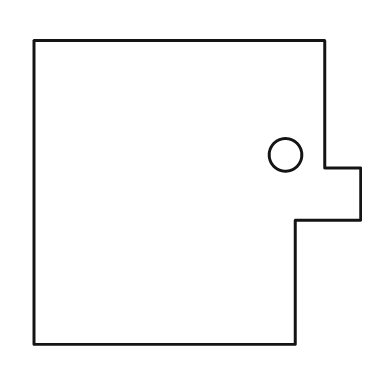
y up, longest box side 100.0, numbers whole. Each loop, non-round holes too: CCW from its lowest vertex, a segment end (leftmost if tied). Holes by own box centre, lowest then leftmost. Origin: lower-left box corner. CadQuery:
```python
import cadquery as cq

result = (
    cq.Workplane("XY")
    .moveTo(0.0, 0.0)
    .lineTo(80.0, 0.0)
    .lineTo(80.0, 38.0)
    .lineTo(100.0, 38.0)
    .lineTo(100.0, 54.0)
    .lineTo(89.0, 54.0)
    .lineTo(89.0, 93.0)
    .lineTo(0.0, 93.0)
    .close()
    .moveTo(77.0, 58.0)
    .circle(5.0)
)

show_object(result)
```